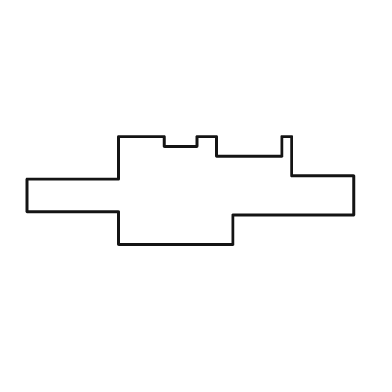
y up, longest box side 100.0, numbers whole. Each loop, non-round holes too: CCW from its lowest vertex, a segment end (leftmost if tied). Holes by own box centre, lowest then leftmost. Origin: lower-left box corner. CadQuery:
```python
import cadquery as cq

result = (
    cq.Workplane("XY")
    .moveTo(28.0, 0.0)
    .lineTo(63.0, 0.0)
    .lineTo(63.0, 9.0)
    .lineTo(100.0, 9.0)
    .lineTo(100.0, 21.0)
    .lineTo(81.0, 21.0)
    .lineTo(81.0, 33.0)
    .lineTo(78.0, 33.0)
    .lineTo(78.0, 27.0)
    .lineTo(58.0, 27.0)
    .lineTo(58.0, 33.0)
    .lineTo(52.0, 33.0)
    .lineTo(52.0, 30.0)
    .lineTo(42.0, 30.0)
    .lineTo(42.0, 33.0)
    .lineTo(28.0, 33.0)
    .lineTo(28.0, 20.0)
    .lineTo(0.0, 20.0)
    .lineTo(0.0, 10.0)
    .lineTo(28.0, 10.0)
    .close()
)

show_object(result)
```